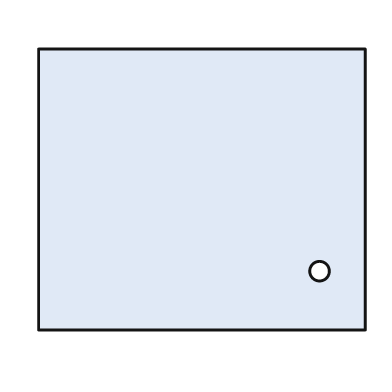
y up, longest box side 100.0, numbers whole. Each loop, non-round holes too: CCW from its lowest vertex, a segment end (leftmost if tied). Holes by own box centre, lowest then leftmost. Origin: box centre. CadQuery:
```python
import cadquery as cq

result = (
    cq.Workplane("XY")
    .moveTo(-50.0, -43.0)
    .lineTo(50.0, -43.0)
    .lineTo(50.0, 43.0)
    .lineTo(-50.0, 43.0)
    .close()
    .moveTo(36.0, -25.0)
    .circle(3.0)
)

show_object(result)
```